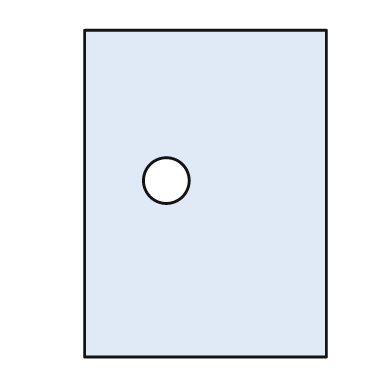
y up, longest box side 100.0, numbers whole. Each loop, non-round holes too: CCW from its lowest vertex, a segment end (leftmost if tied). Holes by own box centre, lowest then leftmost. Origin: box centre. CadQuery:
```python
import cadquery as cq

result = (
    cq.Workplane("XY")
    .moveTo(-37.0, -50.0)
    .lineTo(37.0, -50.0)
    .lineTo(37.0, 50.0)
    .lineTo(-37.0, 50.0)
    .close()
    .moveTo(-12.0, 4.0)
    .circle(7.0)
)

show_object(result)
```